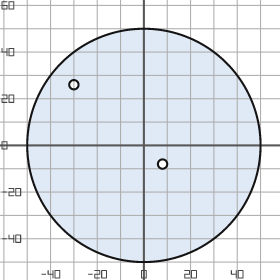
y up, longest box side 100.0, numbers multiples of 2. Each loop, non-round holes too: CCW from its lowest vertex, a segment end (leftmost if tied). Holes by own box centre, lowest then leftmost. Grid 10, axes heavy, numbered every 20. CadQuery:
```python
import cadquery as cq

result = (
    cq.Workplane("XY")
    .moveTo(0.0, 0.0)
    .circle(50.0)
    .moveTo(8.0, -8.0)
    .circle(2.0)
    .moveTo(-30.0, 26.0)
    .circle(2.0)
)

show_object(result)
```